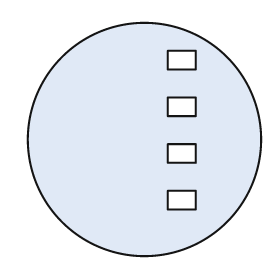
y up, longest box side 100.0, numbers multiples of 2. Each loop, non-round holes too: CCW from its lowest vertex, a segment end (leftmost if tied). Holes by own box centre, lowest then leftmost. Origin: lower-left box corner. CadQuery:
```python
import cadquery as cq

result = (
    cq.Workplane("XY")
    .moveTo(50.0, 50.0)
    .circle(50.0)
    .moveTo(60.0, 20.0)
    .lineTo(72.0, 20.0)
    .lineTo(72.0, 28.0)
    .lineTo(60.0, 28.0)
    .close()
    .moveTo(60.0, 40.0)
    .lineTo(72.0, 40.0)
    .lineTo(72.0, 48.0)
    .lineTo(60.0, 48.0)
    .close()
    .moveTo(60.0, 60.0)
    .lineTo(72.0, 60.0)
    .lineTo(72.0, 68.0)
    .lineTo(60.0, 68.0)
    .close()
    .moveTo(60.0, 80.0)
    .lineTo(72.0, 80.0)
    .lineTo(72.0, 88.0)
    .lineTo(60.0, 88.0)
    .close()
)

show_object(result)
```